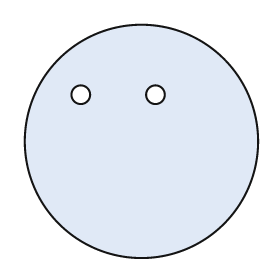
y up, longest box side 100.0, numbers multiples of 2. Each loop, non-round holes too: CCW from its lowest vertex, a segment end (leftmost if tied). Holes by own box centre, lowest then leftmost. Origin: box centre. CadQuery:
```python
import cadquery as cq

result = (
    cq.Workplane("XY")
    .moveTo(0.0, 0.0)
    .circle(50.0)
    .moveTo(-26.0, 20.0)
    .circle(4.0)
    .moveTo(6.0, 20.0)
    .circle(4.0)
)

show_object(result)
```